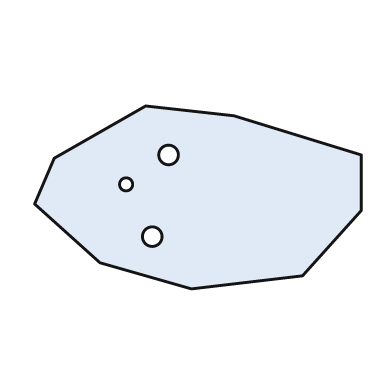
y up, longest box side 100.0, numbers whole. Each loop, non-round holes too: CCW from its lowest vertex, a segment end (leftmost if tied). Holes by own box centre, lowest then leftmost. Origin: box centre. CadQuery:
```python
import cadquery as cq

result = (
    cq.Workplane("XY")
    .moveTo(-2.0, -28.0)
    .lineTo(32.0, -24.0)
    .lineTo(50.0, -4.0)
    .lineTo(50.0, 13.0)
    .lineTo(11.0, 25.0)
    .lineTo(-16.0, 28.0)
    .lineTo(-44.0, 12.0)
    .lineTo(-50.0, -2.0)
    .lineTo(-30.0, -20.0)
    .close()
    .moveTo(-14.0, -12.0)
    .circle(3.0)
    .moveTo(-22.0, 4.0)
    .circle(2.0)
    .moveTo(-9.0, 13.0)
    .circle(3.0)
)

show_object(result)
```